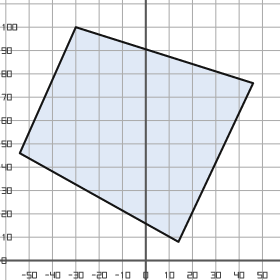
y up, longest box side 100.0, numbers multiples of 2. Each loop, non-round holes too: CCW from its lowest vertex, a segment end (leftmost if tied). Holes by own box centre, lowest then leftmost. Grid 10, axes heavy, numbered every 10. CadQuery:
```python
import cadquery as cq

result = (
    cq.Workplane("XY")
    .moveTo(14.0, 8.0)
    .lineTo(46.0, 76.0)
    .lineTo(-30.0, 100.0)
    .lineTo(-54.0, 46.0)
    .close()
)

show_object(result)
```